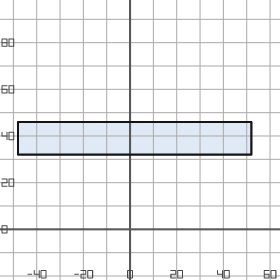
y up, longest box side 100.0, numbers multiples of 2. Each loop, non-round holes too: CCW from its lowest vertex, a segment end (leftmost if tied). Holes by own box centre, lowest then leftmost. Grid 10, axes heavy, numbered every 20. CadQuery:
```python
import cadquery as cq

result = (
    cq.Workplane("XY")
    .moveTo(-48.0, 32.0)
    .lineTo(52.0, 32.0)
    .lineTo(52.0, 46.0)
    .lineTo(-48.0, 46.0)
    .close()
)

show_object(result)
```